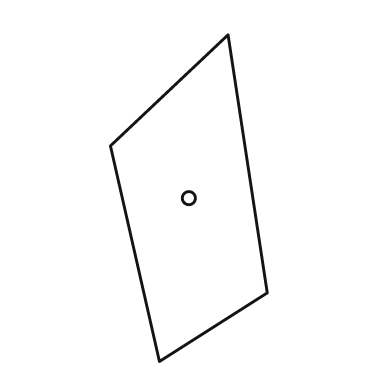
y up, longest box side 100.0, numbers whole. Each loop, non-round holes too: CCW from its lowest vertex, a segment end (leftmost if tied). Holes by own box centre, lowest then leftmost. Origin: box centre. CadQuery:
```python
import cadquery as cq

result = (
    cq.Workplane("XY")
    .moveTo(-9.0, -50.0)
    .lineTo(24.0, -29.0)
    .lineTo(12.0, 50.0)
    .lineTo(-24.0, 16.0)
    .close()
    .moveTo(0.0, 0.0)
    .circle(2.0)
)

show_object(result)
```